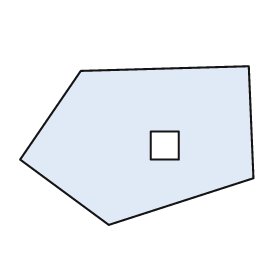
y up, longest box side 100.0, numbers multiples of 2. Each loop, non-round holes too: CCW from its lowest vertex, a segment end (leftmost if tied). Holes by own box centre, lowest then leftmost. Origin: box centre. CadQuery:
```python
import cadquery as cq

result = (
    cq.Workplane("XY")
    .moveTo(-12.0, -34.0)
    .lineTo(50.0, -14.0)
    .lineTo(48.0, 34.0)
    .lineTo(-24.0, 32.0)
    .lineTo(-50.0, -6.0)
    .close()
    .moveTo(6.0, -6.0)
    .lineTo(18.0, -6.0)
    .lineTo(18.0, 6.0)
    .lineTo(6.0, 6.0)
    .close()
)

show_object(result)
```